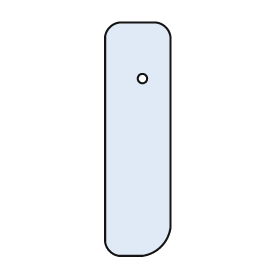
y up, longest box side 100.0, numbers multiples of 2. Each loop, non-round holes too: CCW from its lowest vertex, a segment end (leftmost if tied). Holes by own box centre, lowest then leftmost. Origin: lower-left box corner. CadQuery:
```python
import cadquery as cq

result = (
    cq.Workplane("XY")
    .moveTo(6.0, 0.0)
    .lineTo(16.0, 0.0)
    .threePointArc((24.0, 4.0), (28.0, 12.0))
    .lineTo(28.0, 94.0)
    .threePointArc((26.0, 98.0), (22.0, 100.0))
    .lineTo(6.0, 100.0)
    .threePointArc((2.0, 98.0), (0.0, 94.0))
    .lineTo(0.0, 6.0)
    .threePointArc((2.0, 2.0), (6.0, 0.0))
    .close()
    .moveTo(16.0, 76.0)
    .circle(2.0)
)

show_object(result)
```